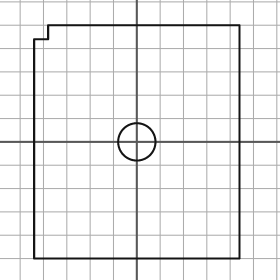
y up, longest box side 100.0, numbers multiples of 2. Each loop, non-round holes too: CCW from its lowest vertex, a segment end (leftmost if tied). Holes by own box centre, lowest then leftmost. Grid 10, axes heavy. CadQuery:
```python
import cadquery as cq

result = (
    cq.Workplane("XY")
    .moveTo(-44.0, -50.0)
    .lineTo(44.0, -50.0)
    .lineTo(44.0, 50.0)
    .lineTo(-38.0, 50.0)
    .lineTo(-38.0, 44.0)
    .lineTo(-44.0, 44.0)
    .close()
    .moveTo(0.0, 0.0)
    .circle(8.0)
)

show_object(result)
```